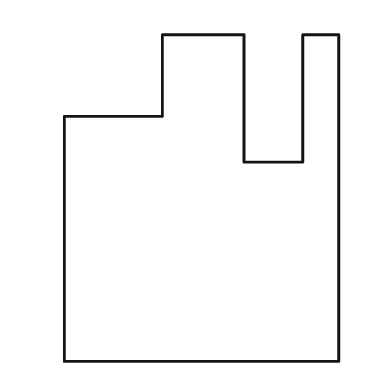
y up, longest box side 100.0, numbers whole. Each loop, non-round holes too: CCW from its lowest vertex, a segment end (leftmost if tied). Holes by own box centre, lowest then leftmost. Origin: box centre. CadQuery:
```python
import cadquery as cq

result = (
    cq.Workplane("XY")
    .moveTo(-42.0, -50.0)
    .lineTo(42.0, -50.0)
    .lineTo(42.0, 50.0)
    .lineTo(31.0, 50.0)
    .lineTo(31.0, 11.0)
    .lineTo(13.0, 11.0)
    .lineTo(13.0, 50.0)
    .lineTo(-12.0, 50.0)
    .lineTo(-12.0, 25.0)
    .lineTo(-42.0, 25.0)
    .close()
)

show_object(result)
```